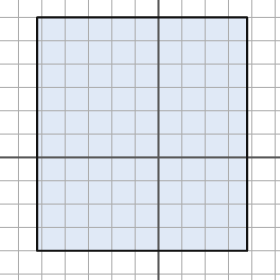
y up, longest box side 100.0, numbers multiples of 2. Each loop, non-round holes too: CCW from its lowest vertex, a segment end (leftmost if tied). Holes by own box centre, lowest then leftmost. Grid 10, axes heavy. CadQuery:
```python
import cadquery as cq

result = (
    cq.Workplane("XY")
    .moveTo(-52.0, -40.0)
    .lineTo(38.0, -40.0)
    .lineTo(38.0, 60.0)
    .lineTo(-52.0, 60.0)
    .close()
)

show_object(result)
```